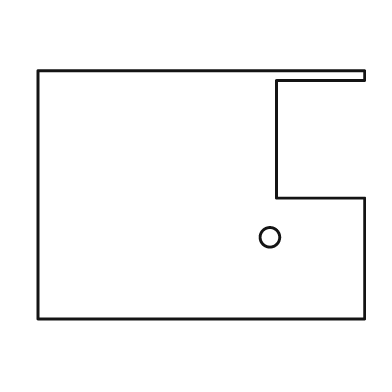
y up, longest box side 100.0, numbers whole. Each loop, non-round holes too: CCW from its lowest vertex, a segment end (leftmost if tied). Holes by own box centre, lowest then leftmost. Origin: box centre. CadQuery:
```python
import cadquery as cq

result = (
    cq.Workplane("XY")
    .moveTo(-50.0, -38.0)
    .lineTo(50.0, -38.0)
    .lineTo(50.0, -1.0)
    .lineTo(23.0, -1.0)
    .lineTo(23.0, 35.0)
    .lineTo(50.0, 35.0)
    .lineTo(50.0, 38.0)
    .lineTo(-50.0, 38.0)
    .close()
    .moveTo(21.0, -13.0)
    .circle(3.0)
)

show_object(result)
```